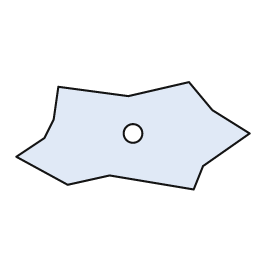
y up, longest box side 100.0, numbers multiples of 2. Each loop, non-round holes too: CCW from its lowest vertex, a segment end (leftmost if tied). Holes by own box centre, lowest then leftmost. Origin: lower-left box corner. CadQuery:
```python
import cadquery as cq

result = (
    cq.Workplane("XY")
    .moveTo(76.0, 0.0)
    .lineTo(80.0, 10.0)
    .lineTo(100.0, 24.0)
    .lineTo(84.0, 34.0)
    .lineTo(74.0, 46.0)
    .lineTo(48.0, 40.0)
    .lineTo(18.0, 44.0)
    .lineTo(16.0, 30.0)
    .lineTo(12.0, 22.0)
    .lineTo(0.0, 14.0)
    .lineTo(22.0, 2.0)
    .lineTo(40.0, 6.0)
    .close()
    .moveTo(50.0, 24.0)
    .circle(4.0)
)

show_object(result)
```